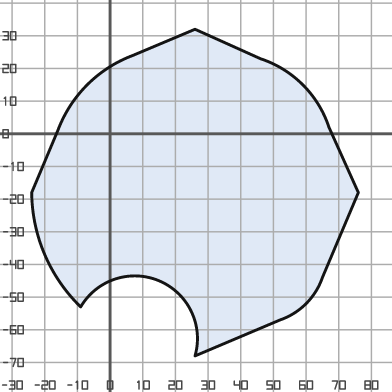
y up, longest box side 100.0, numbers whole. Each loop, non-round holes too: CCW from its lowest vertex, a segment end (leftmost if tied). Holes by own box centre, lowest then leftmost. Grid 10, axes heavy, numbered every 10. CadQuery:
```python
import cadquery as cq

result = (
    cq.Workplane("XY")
    .moveTo(26.0, -68.0)
    .lineTo(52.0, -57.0)
    .threePointArc((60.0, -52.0), (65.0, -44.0))
    .lineTo(76.0, -18.0)
    .lineTo(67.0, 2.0)
    .threePointArc((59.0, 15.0), (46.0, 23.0))
    .lineTo(26.0, 32.0)
    .lineTo(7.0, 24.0)
    .threePointArc((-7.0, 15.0), (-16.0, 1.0))
    .lineTo(-24.0, -18.0)
    .threePointArc((-20.0, -37.0), (-9.0, -53.0))
    .threePointArc((15.0, -45.0), (26.0, -68.0))
    .close()
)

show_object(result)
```